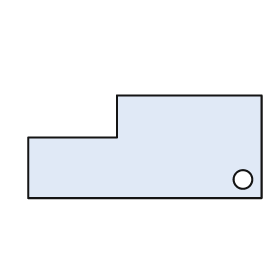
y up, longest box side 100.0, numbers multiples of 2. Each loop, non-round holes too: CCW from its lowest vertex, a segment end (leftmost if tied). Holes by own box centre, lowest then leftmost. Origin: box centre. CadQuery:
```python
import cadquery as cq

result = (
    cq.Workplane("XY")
    .moveTo(-50.0, -22.0)
    .lineTo(50.0, -22.0)
    .lineTo(50.0, 22.0)
    .lineTo(-12.0, 22.0)
    .lineTo(-12.0, 4.0)
    .lineTo(-50.0, 4.0)
    .close()
    .moveTo(42.0, -14.0)
    .circle(4.0)
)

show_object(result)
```